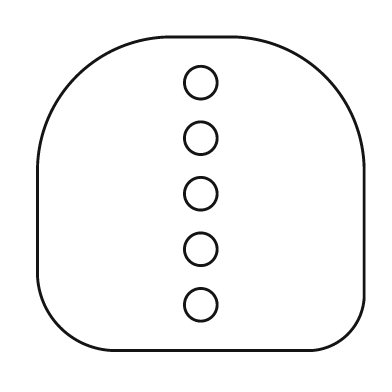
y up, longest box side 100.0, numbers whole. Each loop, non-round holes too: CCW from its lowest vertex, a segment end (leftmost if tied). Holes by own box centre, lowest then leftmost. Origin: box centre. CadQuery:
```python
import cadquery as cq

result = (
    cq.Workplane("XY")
    .moveTo(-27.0, -48.0)
    .lineTo(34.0, -48.0)
    .threePointArc((45.0, -43.0), (50.0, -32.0))
    .lineTo(50.0, 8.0)
    .threePointArc((38.0, 36.0), (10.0, 48.0))
    .lineTo(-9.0, 48.0)
    .threePointArc((-38.0, 36.0), (-50.0, 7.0))
    .lineTo(-50.0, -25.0)
    .threePointArc((-43.0, -41.0), (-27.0, -48.0))
    .close()
    .moveTo(0.0, -34.0)
    .circle(5.0)
    .moveTo(0.0, -17.0)
    .circle(5.0)
    .moveTo(0.0, 0.0)
    .circle(5.0)
    .moveTo(0.0, 17.0)
    .circle(5.0)
    .moveTo(0.0, 34.0)
    .circle(5.0)
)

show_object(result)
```